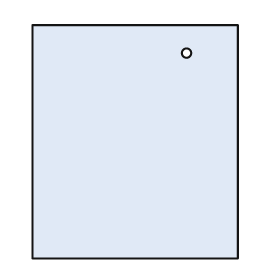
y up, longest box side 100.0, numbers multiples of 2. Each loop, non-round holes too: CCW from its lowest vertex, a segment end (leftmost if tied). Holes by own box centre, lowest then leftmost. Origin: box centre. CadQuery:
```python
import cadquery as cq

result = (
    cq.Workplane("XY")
    .moveTo(-44.0, -50.0)
    .lineTo(44.0, -50.0)
    .lineTo(44.0, 50.0)
    .lineTo(-44.0, 50.0)
    .close()
    .moveTo(22.0, 38.0)
    .circle(2.0)
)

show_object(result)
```